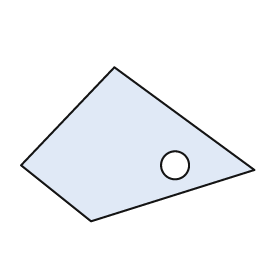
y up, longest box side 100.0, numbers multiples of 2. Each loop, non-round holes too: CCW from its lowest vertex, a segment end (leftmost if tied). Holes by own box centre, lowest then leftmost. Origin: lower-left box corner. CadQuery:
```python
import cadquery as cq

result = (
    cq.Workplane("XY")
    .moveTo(30.0, 0.0)
    .lineTo(100.0, 22.0)
    .lineTo(40.0, 66.0)
    .lineTo(0.0, 24.0)
    .close()
    .moveTo(66.0, 24.0)
    .circle(6.0)
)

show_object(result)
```